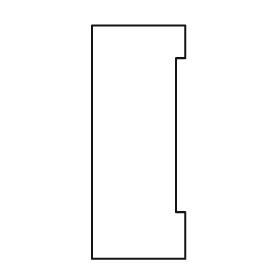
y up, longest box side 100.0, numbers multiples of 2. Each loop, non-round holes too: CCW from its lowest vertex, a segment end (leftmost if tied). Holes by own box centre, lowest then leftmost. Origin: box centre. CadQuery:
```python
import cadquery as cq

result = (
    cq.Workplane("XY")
    .moveTo(-20.0, -50.0)
    .lineTo(20.0, -50.0)
    .lineTo(20.0, -30.0)
    .lineTo(16.0, -30.0)
    .lineTo(16.0, 36.0)
    .lineTo(20.0, 36.0)
    .lineTo(20.0, 50.0)
    .lineTo(-20.0, 50.0)
    .close()
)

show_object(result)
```